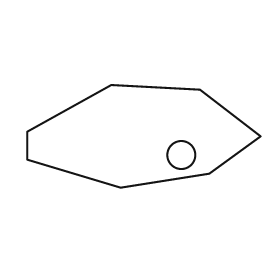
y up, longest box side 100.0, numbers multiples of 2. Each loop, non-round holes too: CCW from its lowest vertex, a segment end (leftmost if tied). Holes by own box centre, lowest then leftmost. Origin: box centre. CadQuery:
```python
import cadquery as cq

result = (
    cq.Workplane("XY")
    .moveTo(-10.0, -22.0)
    .lineTo(28.0, -16.0)
    .lineTo(50.0, 0.0)
    .lineTo(24.0, 20.0)
    .lineTo(-14.0, 22.0)
    .lineTo(-50.0, 2.0)
    .lineTo(-50.0, -10.0)
    .close()
    .moveTo(16.0, -8.0)
    .circle(6.0)
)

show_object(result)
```